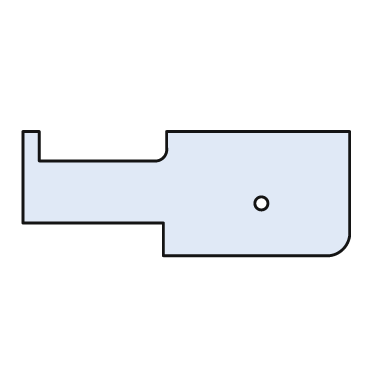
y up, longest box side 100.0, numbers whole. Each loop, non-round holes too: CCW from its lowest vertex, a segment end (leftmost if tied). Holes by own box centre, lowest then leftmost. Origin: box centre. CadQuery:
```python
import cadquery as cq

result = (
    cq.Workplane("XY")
    .moveTo(-7.0, -19.0)
    .lineTo(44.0, -19.0)
    .threePointArc((48.0, -17.0), (50.0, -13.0))
    .lineTo(50.0, 19.0)
    .lineTo(-6.0, 19.0)
    .lineTo(-6.0, 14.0)
    .threePointArc((-7.0, 11.0), (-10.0, 10.0))
    .lineTo(-45.0, 10.0)
    .lineTo(-45.0, 19.0)
    .lineTo(-50.0, 19.0)
    .lineTo(-50.0, -9.0)
    .lineTo(-7.0, -9.0)
    .close()
    .moveTo(23.0, -3.0)
    .circle(2.0)
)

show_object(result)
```